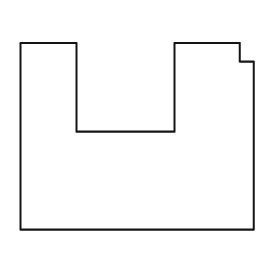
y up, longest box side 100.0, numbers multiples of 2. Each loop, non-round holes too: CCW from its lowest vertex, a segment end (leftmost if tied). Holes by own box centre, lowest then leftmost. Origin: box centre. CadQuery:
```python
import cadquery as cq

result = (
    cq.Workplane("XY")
    .moveTo(-50.0, -40.0)
    .lineTo(50.0, -40.0)
    .lineTo(50.0, 32.0)
    .lineTo(44.0, 32.0)
    .lineTo(44.0, 40.0)
    .lineTo(16.0, 40.0)
    .lineTo(16.0, 2.0)
    .lineTo(-26.0, 2.0)
    .lineTo(-26.0, 40.0)
    .lineTo(-50.0, 40.0)
    .close()
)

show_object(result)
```